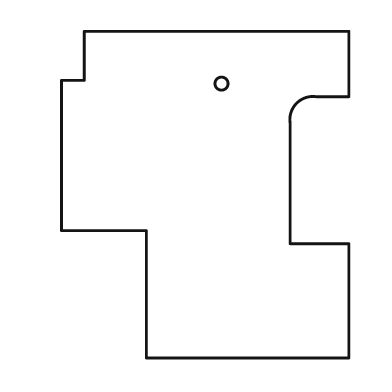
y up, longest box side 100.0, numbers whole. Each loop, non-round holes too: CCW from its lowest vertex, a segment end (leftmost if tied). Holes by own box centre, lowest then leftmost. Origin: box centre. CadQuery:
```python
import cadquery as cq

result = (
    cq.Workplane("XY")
    .moveTo(-18.0, -50.0)
    .lineTo(44.0, -50.0)
    .lineTo(44.0, -15.0)
    .lineTo(26.0, -15.0)
    .lineTo(26.0, 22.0)
    .threePointArc((28.0, 28.0), (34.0, 30.0))
    .lineTo(44.0, 30.0)
    .lineTo(44.0, 50.0)
    .lineTo(-37.0, 50.0)
    .lineTo(-37.0, 35.0)
    .lineTo(-44.0, 35.0)
    .lineTo(-44.0, -11.0)
    .lineTo(-18.0, -11.0)
    .close()
    .moveTo(5.0, 34.0)
    .circle(2.0)
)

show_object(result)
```